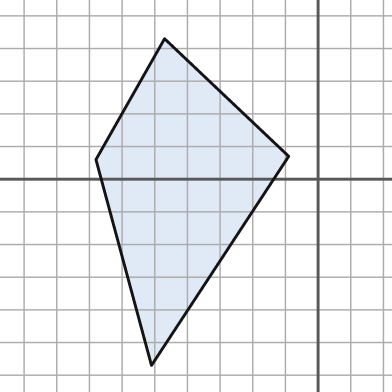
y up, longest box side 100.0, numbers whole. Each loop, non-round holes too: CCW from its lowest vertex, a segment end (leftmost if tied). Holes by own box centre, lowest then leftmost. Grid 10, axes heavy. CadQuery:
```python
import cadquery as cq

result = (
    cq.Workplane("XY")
    .moveTo(-51.0, -57.0)
    .lineTo(-9.0, 7.0)
    .lineTo(-47.0, 43.0)
    .lineTo(-68.0, 6.0)
    .close()
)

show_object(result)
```